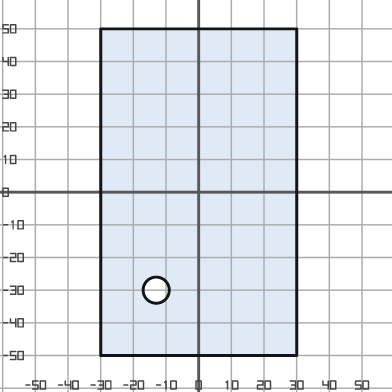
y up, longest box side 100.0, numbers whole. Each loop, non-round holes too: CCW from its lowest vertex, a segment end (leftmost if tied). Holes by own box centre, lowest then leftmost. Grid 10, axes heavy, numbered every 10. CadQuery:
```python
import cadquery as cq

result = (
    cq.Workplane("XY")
    .moveTo(-30.0, -50.0)
    .lineTo(30.0, -50.0)
    .lineTo(30.0, 50.0)
    .lineTo(-30.0, 50.0)
    .close()
    .moveTo(-13.0, -30.0)
    .circle(4.0)
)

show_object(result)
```